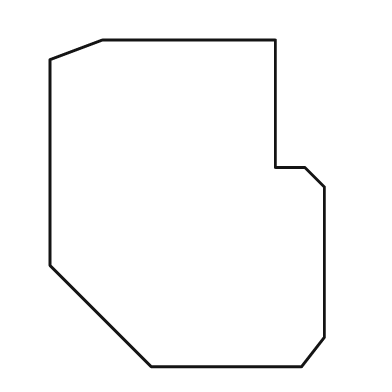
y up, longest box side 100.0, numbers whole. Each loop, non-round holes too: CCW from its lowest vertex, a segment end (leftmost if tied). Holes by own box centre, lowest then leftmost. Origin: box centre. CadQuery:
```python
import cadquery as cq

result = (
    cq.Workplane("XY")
    .moveTo(-11.0, -50.0)
    .lineTo(35.0, -50.0)
    .lineTo(42.0, -41.0)
    .lineTo(42.0, 5.0)
    .lineTo(36.0, 11.0)
    .lineTo(27.0, 11.0)
    .lineTo(27.0, 50.0)
    .lineTo(-26.0, 50.0)
    .lineTo(-42.0, 44.0)
    .lineTo(-42.0, -19.0)
    .close()
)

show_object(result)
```